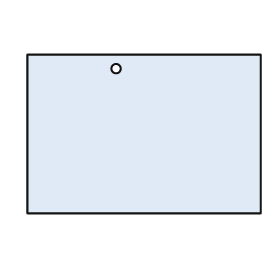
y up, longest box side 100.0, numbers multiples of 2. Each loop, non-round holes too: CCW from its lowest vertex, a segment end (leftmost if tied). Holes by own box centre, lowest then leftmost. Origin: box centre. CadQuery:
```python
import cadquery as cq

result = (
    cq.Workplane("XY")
    .moveTo(-50.0, -34.0)
    .lineTo(50.0, -34.0)
    .lineTo(50.0, 34.0)
    .lineTo(-50.0, 34.0)
    .close()
    .moveTo(-12.0, 28.0)
    .circle(2.0)
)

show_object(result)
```